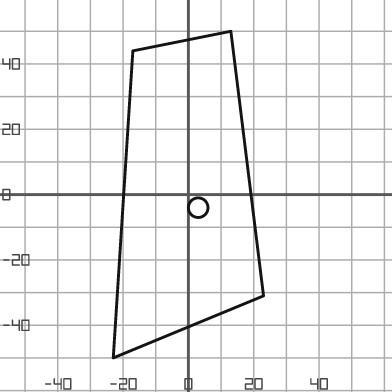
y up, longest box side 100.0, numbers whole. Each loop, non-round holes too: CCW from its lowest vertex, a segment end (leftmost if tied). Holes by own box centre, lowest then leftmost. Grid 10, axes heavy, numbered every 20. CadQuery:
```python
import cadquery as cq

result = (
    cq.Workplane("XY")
    .moveTo(-23.0, -50.0)
    .lineTo(23.0, -31.0)
    .lineTo(13.0, 50.0)
    .lineTo(-17.0, 44.0)
    .close()
    .moveTo(3.0, -4.0)
    .circle(3.0)
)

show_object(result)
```